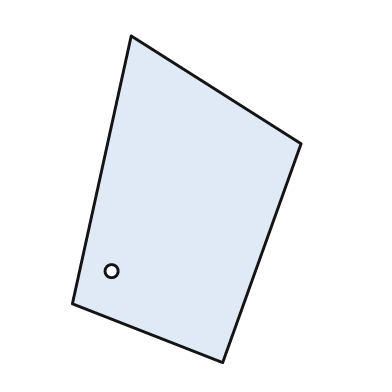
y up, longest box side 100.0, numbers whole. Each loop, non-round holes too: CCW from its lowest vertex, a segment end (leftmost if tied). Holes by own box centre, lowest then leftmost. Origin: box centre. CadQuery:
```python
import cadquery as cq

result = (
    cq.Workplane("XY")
    .moveTo(11.0, -50.0)
    .lineTo(35.0, 17.0)
    .lineTo(-17.0, 50.0)
    .lineTo(-35.0, -32.0)
    .close()
    .moveTo(-23.0, -22.0)
    .circle(2.0)
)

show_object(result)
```